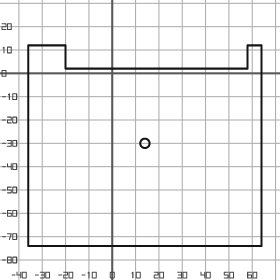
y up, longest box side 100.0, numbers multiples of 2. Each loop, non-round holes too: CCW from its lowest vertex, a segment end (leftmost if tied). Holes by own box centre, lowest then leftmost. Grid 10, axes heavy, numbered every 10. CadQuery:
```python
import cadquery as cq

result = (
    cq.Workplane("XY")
    .moveTo(-36.0, -74.0)
    .lineTo(64.0, -74.0)
    .lineTo(64.0, 12.0)
    .lineTo(58.0, 12.0)
    .lineTo(58.0, 2.0)
    .lineTo(-20.0, 2.0)
    .lineTo(-20.0, 12.0)
    .lineTo(-36.0, 12.0)
    .close()
    .moveTo(14.0, -30.0)
    .circle(2.0)
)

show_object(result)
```